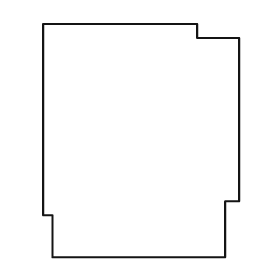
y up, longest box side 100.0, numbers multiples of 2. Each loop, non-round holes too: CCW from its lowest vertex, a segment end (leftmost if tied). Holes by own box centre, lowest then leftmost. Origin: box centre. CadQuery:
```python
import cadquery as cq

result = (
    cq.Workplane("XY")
    .moveTo(-38.0, -50.0)
    .lineTo(36.0, -50.0)
    .lineTo(36.0, -26.0)
    .lineTo(42.0, -26.0)
    .lineTo(42.0, 44.0)
    .lineTo(24.0, 44.0)
    .lineTo(24.0, 50.0)
    .lineTo(-42.0, 50.0)
    .lineTo(-42.0, -32.0)
    .lineTo(-38.0, -32.0)
    .close()
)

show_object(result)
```